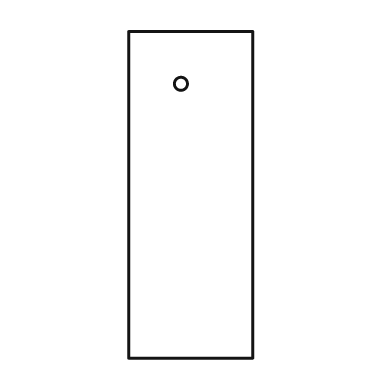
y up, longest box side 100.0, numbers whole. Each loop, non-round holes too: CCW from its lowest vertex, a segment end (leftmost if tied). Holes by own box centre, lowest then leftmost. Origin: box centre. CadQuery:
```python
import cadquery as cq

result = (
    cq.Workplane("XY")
    .moveTo(-19.0, -50.0)
    .lineTo(19.0, -50.0)
    .lineTo(19.0, 50.0)
    .lineTo(-19.0, 50.0)
    .close()
    .moveTo(-3.0, 34.0)
    .circle(2.0)
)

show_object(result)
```